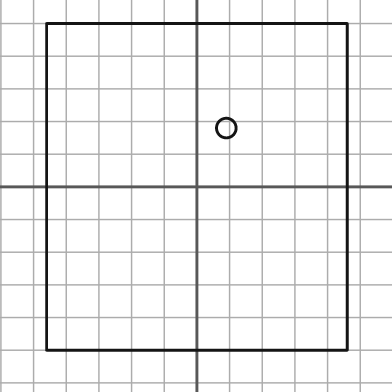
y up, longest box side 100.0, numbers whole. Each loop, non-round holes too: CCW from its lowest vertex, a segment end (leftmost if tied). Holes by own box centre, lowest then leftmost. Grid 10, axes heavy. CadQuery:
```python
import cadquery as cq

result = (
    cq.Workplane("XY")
    .moveTo(-46.0, -50.0)
    .lineTo(46.0, -50.0)
    .lineTo(46.0, 50.0)
    .lineTo(-46.0, 50.0)
    .close()
    .moveTo(9.0, 18.0)
    .circle(3.0)
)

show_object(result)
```